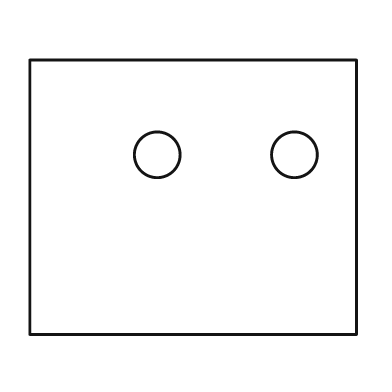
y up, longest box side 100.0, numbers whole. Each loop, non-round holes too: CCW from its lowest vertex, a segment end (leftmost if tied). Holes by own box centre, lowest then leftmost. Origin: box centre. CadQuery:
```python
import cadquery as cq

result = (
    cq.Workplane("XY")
    .moveTo(-50.0, -42.0)
    .lineTo(50.0, -42.0)
    .lineTo(50.0, 42.0)
    .lineTo(-50.0, 42.0)
    .close()
    .moveTo(-11.0, 13.0)
    .circle(7.0)
    .moveTo(31.0, 13.0)
    .circle(7.0)
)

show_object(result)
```